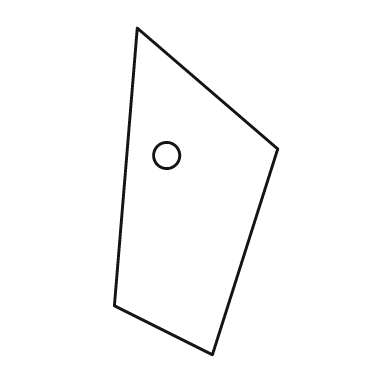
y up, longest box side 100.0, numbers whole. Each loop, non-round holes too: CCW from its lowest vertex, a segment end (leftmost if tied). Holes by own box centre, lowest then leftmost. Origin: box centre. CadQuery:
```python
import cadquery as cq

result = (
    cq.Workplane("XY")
    .moveTo(5.0, -50.0)
    .lineTo(25.0, 13.0)
    .lineTo(-18.0, 50.0)
    .lineTo(-25.0, -35.0)
    .close()
    .moveTo(-9.0, 11.0)
    .circle(4.0)
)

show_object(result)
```